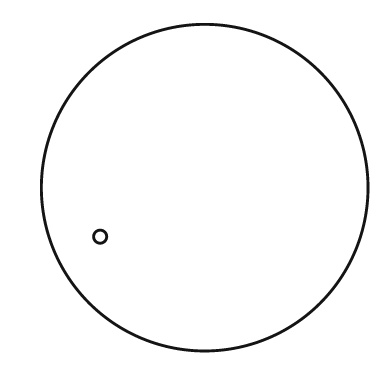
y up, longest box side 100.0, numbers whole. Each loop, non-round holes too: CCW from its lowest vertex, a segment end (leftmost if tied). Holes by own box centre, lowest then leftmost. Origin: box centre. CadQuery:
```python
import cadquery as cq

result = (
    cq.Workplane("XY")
    .moveTo(0.0, 0.0)
    .circle(50.0)
    .moveTo(-32.0, -15.0)
    .circle(2.0)
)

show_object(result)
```